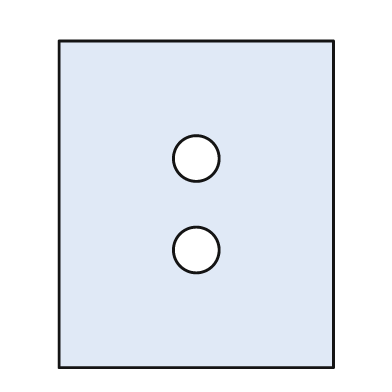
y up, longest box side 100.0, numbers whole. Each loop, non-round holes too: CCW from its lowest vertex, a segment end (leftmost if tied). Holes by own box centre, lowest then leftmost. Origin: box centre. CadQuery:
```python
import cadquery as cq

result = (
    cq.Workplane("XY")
    .moveTo(-42.0, -50.0)
    .lineTo(42.0, -50.0)
    .lineTo(42.0, 50.0)
    .lineTo(-42.0, 50.0)
    .close()
    .moveTo(0.0, -14.0)
    .circle(7.0)
    .moveTo(0.0, 14.0)
    .circle(7.0)
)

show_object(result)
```